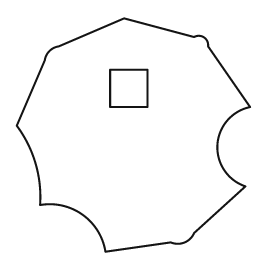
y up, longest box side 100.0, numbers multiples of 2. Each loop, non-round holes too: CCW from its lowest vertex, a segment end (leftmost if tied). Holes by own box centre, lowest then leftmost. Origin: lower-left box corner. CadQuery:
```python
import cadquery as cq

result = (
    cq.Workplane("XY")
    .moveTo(38.0, 0.0)
    .lineTo(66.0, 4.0)
    .threePointArc((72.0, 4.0), (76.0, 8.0))
    .lineTo(98.0, 28.0)
    .threePointArc((86.0, 46.0), (100.0, 62.0))
    .lineTo(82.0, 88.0)
    .threePointArc((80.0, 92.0), (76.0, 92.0))
    .lineTo(46.0, 100.0)
    .lineTo(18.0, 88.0)
    .threePointArc((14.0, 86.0), (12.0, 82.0))
    .lineTo(0.0, 54.0)
    .threePointArc((8.0, 38.0), (10.0, 20.0))
    .threePointArc((28.0, 16.0), (38.0, 0.0))
    .close()
    .moveTo(40.0, 62.0)
    .lineTo(56.0, 62.0)
    .lineTo(56.0, 78.0)
    .lineTo(40.0, 78.0)
    .close()
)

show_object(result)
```